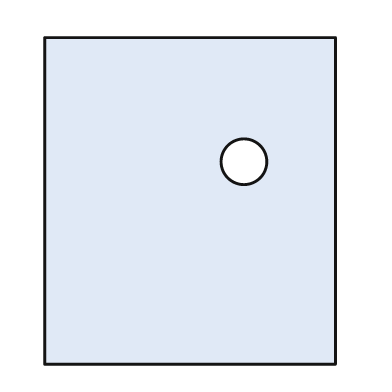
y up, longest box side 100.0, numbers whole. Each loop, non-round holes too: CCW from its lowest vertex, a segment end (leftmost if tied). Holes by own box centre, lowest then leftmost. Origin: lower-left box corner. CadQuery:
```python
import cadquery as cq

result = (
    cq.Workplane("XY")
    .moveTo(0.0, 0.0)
    .lineTo(89.0, 0.0)
    .lineTo(89.0, 100.0)
    .lineTo(0.0, 100.0)
    .close()
    .moveTo(61.0, 62.0)
    .circle(7.0)
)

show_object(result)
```